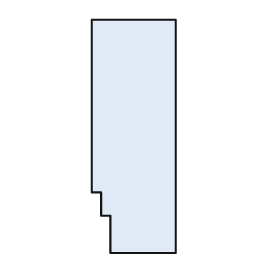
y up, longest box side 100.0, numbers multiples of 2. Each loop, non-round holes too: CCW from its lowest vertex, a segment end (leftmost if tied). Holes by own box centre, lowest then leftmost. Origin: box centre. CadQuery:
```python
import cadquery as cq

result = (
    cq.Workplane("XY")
    .moveTo(-10.0, -50.0)
    .lineTo(18.0, -50.0)
    .lineTo(18.0, 50.0)
    .lineTo(-18.0, 50.0)
    .lineTo(-18.0, -24.0)
    .lineTo(-14.0, -24.0)
    .lineTo(-14.0, -34.0)
    .lineTo(-10.0, -34.0)
    .close()
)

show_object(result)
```